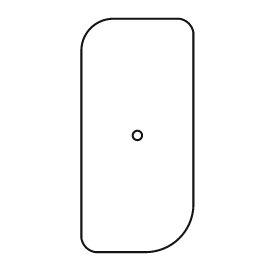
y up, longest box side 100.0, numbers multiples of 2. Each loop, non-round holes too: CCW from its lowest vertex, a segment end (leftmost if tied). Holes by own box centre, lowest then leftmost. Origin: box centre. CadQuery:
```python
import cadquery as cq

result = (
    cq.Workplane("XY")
    .moveTo(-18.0, -50.0)
    .lineTo(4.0, -50.0)
    .threePointArc((18.0, -44.0), (24.0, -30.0))
    .lineTo(24.0, 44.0)
    .threePointArc((22.0, 48.0), (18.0, 50.0))
    .lineTo(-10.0, 50.0)
    .threePointArc((-20.0, 46.0), (-24.0, 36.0))
    .lineTo(-24.0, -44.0)
    .threePointArc((-22.0, -48.0), (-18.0, -50.0))
    .close()
    .moveTo(0.0, 0.0)
    .circle(2.0)
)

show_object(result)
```